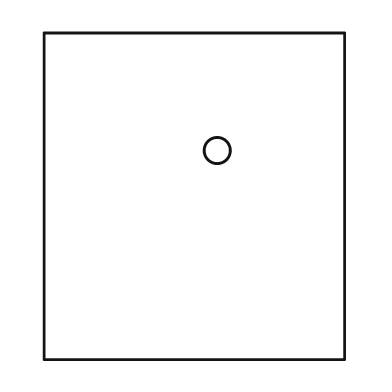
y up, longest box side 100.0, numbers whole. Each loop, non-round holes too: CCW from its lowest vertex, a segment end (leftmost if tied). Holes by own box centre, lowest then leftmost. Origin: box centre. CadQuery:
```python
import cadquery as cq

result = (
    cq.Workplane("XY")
    .moveTo(-46.0, -50.0)
    .lineTo(46.0, -50.0)
    .lineTo(46.0, 50.0)
    .lineTo(-46.0, 50.0)
    .close()
    .moveTo(7.0, 14.0)
    .circle(4.0)
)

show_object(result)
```